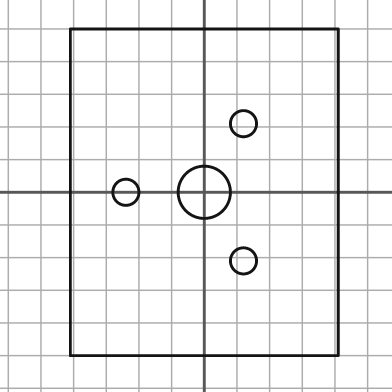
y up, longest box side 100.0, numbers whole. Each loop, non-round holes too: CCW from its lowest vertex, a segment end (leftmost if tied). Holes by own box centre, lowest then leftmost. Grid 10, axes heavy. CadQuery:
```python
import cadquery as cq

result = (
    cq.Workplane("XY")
    .moveTo(-41.0, -50.0)
    .lineTo(41.0, -50.0)
    .lineTo(41.0, 50.0)
    .lineTo(-41.0, 50.0)
    .close()
    .moveTo(12.0, -21.0)
    .circle(4.0)
    .moveTo(-24.0, 0.0)
    .circle(4.0)
    .moveTo(0.0, 0.0)
    .circle(8.0)
    .moveTo(12.0, 21.0)
    .circle(4.0)
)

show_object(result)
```